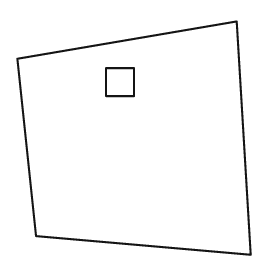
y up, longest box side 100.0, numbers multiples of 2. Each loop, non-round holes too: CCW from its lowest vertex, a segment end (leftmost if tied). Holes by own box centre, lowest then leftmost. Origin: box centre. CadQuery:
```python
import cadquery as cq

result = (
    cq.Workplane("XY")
    .moveTo(50.0, -50.0)
    .lineTo(44.0, 50.0)
    .lineTo(-50.0, 34.0)
    .lineTo(-42.0, -42.0)
    .close()
    .moveTo(-12.0, 18.0)
    .lineTo(0.0, 18.0)
    .lineTo(0.0, 30.0)
    .lineTo(-12.0, 30.0)
    .close()
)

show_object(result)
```